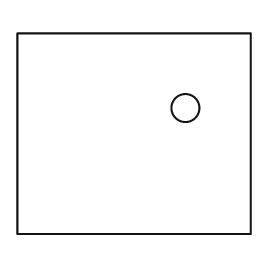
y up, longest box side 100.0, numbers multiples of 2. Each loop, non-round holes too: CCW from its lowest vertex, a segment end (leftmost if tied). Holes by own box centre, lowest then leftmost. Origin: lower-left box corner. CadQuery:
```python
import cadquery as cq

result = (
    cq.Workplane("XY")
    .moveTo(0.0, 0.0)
    .lineTo(100.0, 0.0)
    .lineTo(100.0, 86.0)
    .lineTo(0.0, 86.0)
    .close()
    .moveTo(72.0, 54.0)
    .circle(6.0)
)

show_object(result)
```